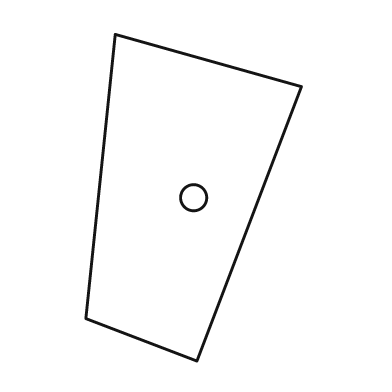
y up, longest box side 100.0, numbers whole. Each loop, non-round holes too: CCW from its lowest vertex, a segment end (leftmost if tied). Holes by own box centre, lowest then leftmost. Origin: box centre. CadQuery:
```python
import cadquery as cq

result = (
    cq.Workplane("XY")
    .moveTo(1.0, -50.0)
    .lineTo(33.0, 34.0)
    .lineTo(-24.0, 50.0)
    .lineTo(-33.0, -37.0)
    .close()
    .moveTo(0.0, 0.0)
    .circle(4.0)
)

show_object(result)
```